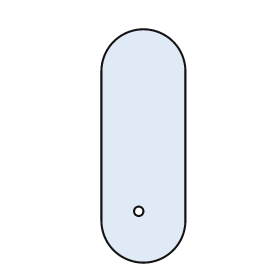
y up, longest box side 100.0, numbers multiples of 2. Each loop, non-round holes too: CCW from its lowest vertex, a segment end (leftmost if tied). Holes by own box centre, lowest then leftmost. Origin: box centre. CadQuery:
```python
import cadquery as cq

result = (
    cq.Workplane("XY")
    .moveTo(-18.0, -32.0)
    .threePointArc((0.0, -50.0), (18.0, -32.0))
    .lineTo(18.0, 32.0)
    .threePointArc((0.0, 50.0), (-18.0, 32.0))
    .close()
    .moveTo(-2.0, -28.0)
    .circle(2.0)
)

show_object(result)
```